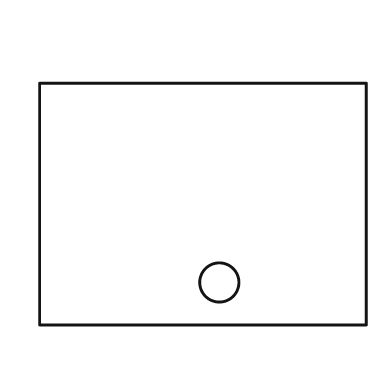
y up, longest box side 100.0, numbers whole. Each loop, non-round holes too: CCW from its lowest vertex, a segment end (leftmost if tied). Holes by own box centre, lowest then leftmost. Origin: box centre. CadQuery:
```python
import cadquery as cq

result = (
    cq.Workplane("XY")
    .moveTo(-50.0, -37.0)
    .lineTo(50.0, -37.0)
    .lineTo(50.0, 37.0)
    .lineTo(-50.0, 37.0)
    .close()
    .moveTo(5.0, -24.0)
    .circle(6.0)
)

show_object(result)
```